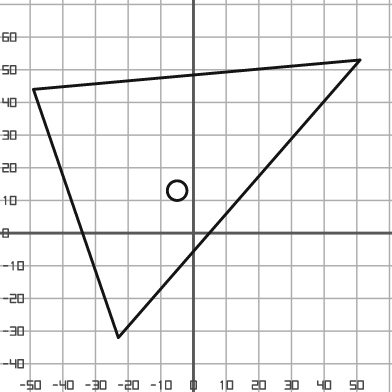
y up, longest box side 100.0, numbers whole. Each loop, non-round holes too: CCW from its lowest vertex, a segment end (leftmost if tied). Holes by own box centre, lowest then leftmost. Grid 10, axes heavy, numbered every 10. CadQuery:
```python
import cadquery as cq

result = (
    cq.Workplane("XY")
    .moveTo(-23.0, -32.0)
    .lineTo(51.0, 53.0)
    .lineTo(-49.0, 44.0)
    .close()
    .moveTo(-5.0, 13.0)
    .circle(3.0)
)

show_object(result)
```